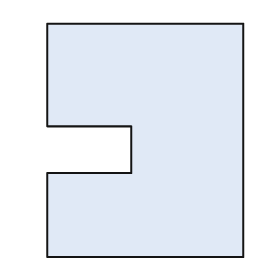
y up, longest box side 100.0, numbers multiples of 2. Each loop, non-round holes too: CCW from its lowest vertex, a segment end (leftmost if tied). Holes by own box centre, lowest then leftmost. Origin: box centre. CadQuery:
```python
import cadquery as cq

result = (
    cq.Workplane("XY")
    .moveTo(-42.0, -50.0)
    .lineTo(42.0, -50.0)
    .lineTo(42.0, 50.0)
    .lineTo(-42.0, 50.0)
    .lineTo(-42.0, 6.0)
    .lineTo(-6.0, 6.0)
    .lineTo(-6.0, -14.0)
    .lineTo(-42.0, -14.0)
    .close()
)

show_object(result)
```